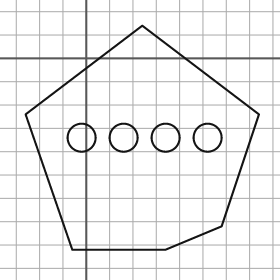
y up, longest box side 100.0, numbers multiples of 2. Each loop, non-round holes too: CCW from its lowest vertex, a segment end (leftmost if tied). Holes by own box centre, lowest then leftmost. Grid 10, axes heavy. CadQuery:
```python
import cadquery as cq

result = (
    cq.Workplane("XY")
    .moveTo(-6.0, -82.0)
    .lineTo(34.0, -82.0)
    .lineTo(58.0, -72.0)
    .lineTo(74.0, -24.0)
    .lineTo(24.0, 14.0)
    .lineTo(-26.0, -24.0)
    .close()
    .moveTo(-2.0, -34.0)
    .circle(6.0)
    .moveTo(16.0, -34.0)
    .circle(6.0)
    .moveTo(34.0, -34.0)
    .circle(6.0)
    .moveTo(52.0, -34.0)
    .circle(6.0)
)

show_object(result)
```